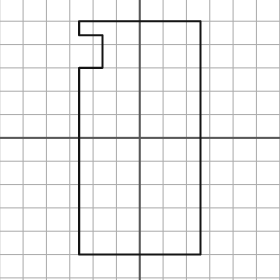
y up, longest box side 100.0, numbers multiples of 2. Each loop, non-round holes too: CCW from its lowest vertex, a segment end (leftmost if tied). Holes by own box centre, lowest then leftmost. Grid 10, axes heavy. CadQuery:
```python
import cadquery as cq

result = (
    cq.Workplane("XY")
    .moveTo(-26.0, -50.0)
    .lineTo(26.0, -50.0)
    .lineTo(26.0, 50.0)
    .lineTo(-26.0, 50.0)
    .lineTo(-26.0, 44.0)
    .lineTo(-16.0, 44.0)
    .lineTo(-16.0, 30.0)
    .lineTo(-26.0, 30.0)
    .close()
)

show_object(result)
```